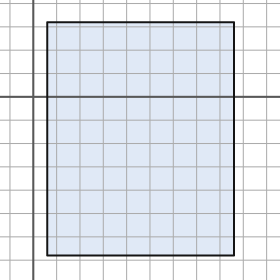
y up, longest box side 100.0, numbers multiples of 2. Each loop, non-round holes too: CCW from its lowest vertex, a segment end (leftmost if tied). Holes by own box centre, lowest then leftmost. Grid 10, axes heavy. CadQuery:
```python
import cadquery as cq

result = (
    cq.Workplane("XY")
    .moveTo(6.0, -68.0)
    .lineTo(86.0, -68.0)
    .lineTo(86.0, 32.0)
    .lineTo(6.0, 32.0)
    .close()
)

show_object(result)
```